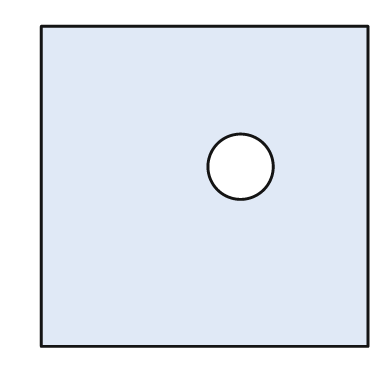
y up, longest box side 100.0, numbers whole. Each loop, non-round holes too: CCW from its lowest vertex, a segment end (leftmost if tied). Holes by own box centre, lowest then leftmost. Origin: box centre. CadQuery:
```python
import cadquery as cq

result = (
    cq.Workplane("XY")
    .moveTo(-50.0, -49.0)
    .lineTo(50.0, -49.0)
    .lineTo(50.0, 49.0)
    .lineTo(-50.0, 49.0)
    .close()
    .moveTo(11.0, 6.0)
    .circle(10.0)
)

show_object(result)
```